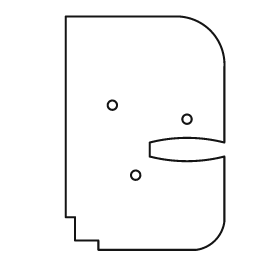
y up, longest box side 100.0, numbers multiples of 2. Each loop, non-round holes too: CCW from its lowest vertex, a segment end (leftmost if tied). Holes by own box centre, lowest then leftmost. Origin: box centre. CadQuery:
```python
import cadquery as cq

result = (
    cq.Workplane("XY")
    .moveTo(-20.0, -50.0)
    .lineTo(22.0, -50.0)
    .threePointArc((30.0, -46.0), (34.0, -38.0))
    .lineTo(34.0, -10.0)
    .threePointArc((18.0, -12.0), (2.0, -10.0))
    .lineTo(2.0, -4.0)
    .threePointArc((18.0, -2.0), (34.0, -4.0))
    .lineTo(34.0, 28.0)
    .threePointArc((28.0, 44.0), (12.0, 50.0))
    .lineTo(-34.0, 50.0)
    .lineTo(-34.0, -36.0)
    .lineTo(-30.0, -36.0)
    .lineTo(-30.0, -46.0)
    .lineTo(-20.0, -46.0)
    .close()
    .moveTo(-4.0, -18.0)
    .circle(2.0)
    .moveTo(18.0, 6.0)
    .circle(2.0)
    .moveTo(-14.0, 12.0)
    .circle(2.0)
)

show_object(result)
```